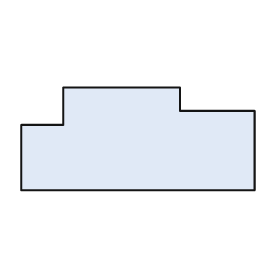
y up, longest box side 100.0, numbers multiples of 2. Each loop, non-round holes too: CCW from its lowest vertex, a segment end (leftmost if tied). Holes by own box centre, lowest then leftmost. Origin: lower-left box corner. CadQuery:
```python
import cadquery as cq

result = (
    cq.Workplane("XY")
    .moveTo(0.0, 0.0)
    .lineTo(100.0, 0.0)
    .lineTo(100.0, 34.0)
    .lineTo(68.0, 34.0)
    .lineTo(68.0, 44.0)
    .lineTo(18.0, 44.0)
    .lineTo(18.0, 28.0)
    .lineTo(0.0, 28.0)
    .close()
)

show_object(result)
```